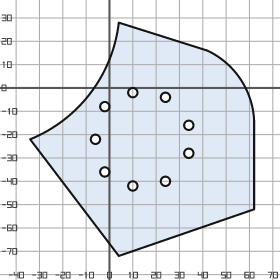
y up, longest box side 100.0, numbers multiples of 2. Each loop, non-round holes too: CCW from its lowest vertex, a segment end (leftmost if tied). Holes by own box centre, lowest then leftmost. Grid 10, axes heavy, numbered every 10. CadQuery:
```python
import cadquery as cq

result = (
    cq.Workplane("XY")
    .moveTo(4.0, -72.0)
    .lineTo(62.0, -52.0)
    .lineTo(62.0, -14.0)
    .threePointArc((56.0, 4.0), (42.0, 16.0))
    .lineTo(4.0, 28.0)
    .threePointArc((-8.0, -2.0), (-34.0, -22.0))
    .close()
    .moveTo(10.0, -42.0)
    .circle(2.0)
    .moveTo(24.0, -40.0)
    .circle(2.0)
    .moveTo(-2.0, -36.0)
    .circle(2.0)
    .moveTo(34.0, -28.0)
    .circle(2.0)
    .moveTo(-6.0, -22.0)
    .circle(2.0)
    .moveTo(34.0, -16.0)
    .circle(2.0)
    .moveTo(-2.0, -8.0)
    .circle(2.0)
    .moveTo(24.0, -4.0)
    .circle(2.0)
    .moveTo(10.0, -2.0)
    .circle(2.0)
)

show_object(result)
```